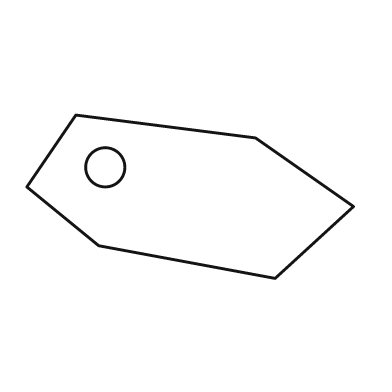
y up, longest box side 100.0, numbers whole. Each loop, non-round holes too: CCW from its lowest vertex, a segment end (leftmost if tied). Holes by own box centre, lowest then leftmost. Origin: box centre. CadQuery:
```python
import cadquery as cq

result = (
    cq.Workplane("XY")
    .moveTo(26.0, -25.0)
    .lineTo(50.0, -3.0)
    .lineTo(20.0, 18.0)
    .lineTo(-35.0, 25.0)
    .lineTo(-50.0, 3.0)
    .lineTo(-28.0, -15.0)
    .close()
    .moveTo(-26.0, 9.0)
    .circle(6.0)
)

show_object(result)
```